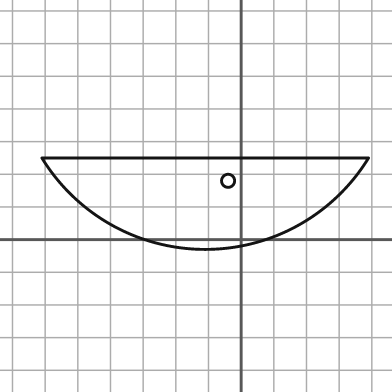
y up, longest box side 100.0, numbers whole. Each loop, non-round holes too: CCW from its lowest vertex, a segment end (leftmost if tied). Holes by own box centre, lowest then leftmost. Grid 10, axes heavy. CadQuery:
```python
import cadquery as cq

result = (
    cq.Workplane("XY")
    .moveTo(-61.0, 25.0)
    .threePointArc((-11.0, -3.0), (39.0, 25.0))
    .close()
    .moveTo(-4.0, 18.0)
    .circle(2.0)
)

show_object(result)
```